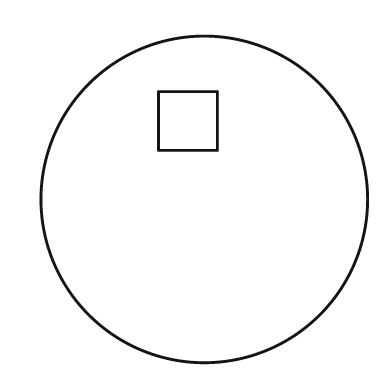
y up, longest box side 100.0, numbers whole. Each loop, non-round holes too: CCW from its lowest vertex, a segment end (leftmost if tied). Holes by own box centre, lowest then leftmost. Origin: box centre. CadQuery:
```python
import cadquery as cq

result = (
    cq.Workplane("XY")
    .moveTo(0.0, 0.0)
    .circle(50.0)
    .moveTo(-14.0, 15.0)
    .lineTo(4.0, 15.0)
    .lineTo(4.0, 33.0)
    .lineTo(-14.0, 33.0)
    .close()
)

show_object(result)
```